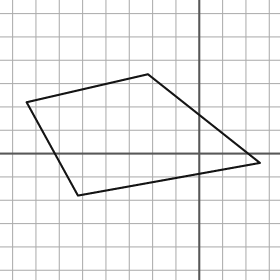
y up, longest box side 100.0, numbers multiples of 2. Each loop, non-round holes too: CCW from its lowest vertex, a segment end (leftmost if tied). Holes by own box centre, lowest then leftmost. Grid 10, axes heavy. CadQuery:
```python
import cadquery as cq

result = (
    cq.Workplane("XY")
    .moveTo(-52.0, -18.0)
    .lineTo(26.0, -4.0)
    .lineTo(-22.0, 34.0)
    .lineTo(-74.0, 22.0)
    .close()
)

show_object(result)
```